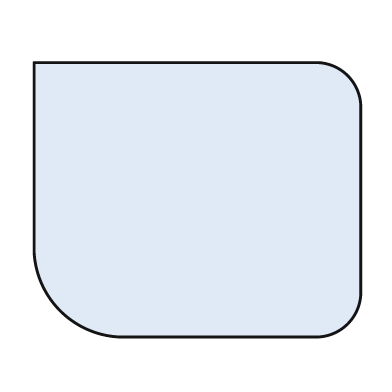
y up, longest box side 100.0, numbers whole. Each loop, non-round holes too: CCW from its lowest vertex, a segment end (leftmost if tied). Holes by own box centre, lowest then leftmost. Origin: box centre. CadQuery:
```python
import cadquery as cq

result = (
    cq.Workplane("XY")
    .moveTo(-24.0, -42.0)
    .lineTo(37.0, -42.0)
    .threePointArc((46.0, -38.0), (50.0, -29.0))
    .lineTo(50.0, 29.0)
    .threePointArc((46.0, 38.0), (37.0, 42.0))
    .lineTo(-50.0, 42.0)
    .lineTo(-50.0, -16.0)
    .threePointArc((-42.0, -34.0), (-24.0, -42.0))
    .close()
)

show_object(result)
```